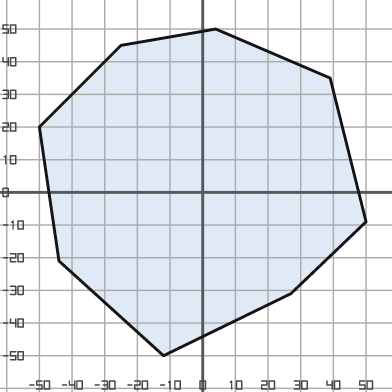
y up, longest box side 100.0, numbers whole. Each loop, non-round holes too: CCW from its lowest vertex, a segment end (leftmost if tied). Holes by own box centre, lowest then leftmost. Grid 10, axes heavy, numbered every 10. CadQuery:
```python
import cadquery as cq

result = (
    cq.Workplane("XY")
    .moveTo(-12.0, -50.0)
    .lineTo(27.0, -31.0)
    .lineTo(50.0, -9.0)
    .lineTo(39.0, 35.0)
    .lineTo(4.0, 50.0)
    .lineTo(-25.0, 45.0)
    .lineTo(-50.0, 20.0)
    .lineTo(-44.0, -21.0)
    .close()
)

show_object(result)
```